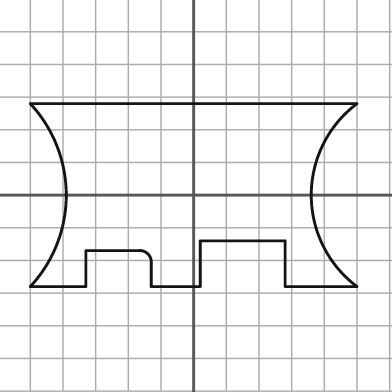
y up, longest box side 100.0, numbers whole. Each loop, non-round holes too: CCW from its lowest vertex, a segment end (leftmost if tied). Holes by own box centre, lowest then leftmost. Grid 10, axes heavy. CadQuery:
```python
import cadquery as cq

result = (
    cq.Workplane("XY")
    .moveTo(-50.0, -28.0)
    .lineTo(-33.0, -28.0)
    .lineTo(-33.0, -17.0)
    .lineTo(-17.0, -17.0)
    .threePointArc((-14.0, -18.0), (-13.0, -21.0))
    .lineTo(-13.0, -28.0)
    .lineTo(2.0, -28.0)
    .lineTo(2.0, -14.0)
    .lineTo(28.0, -14.0)
    .lineTo(28.0, -28.0)
    .lineTo(50.0, -28.0)
    .threePointArc((36.0, 0.0), (50.0, 28.0))
    .lineTo(-50.0, 28.0)
    .threePointArc((-39.0, 0.0), (-50.0, -28.0))
    .close()
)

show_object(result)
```